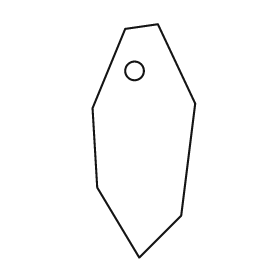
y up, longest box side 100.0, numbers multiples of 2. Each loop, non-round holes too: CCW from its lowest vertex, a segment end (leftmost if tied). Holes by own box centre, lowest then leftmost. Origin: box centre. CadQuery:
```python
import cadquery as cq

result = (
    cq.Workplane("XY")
    .moveTo(-2.0, -50.0)
    .lineTo(16.0, -32.0)
    .lineTo(22.0, 16.0)
    .lineTo(6.0, 50.0)
    .lineTo(-8.0, 48.0)
    .lineTo(-22.0, 14.0)
    .lineTo(-20.0, -20.0)
    .close()
    .moveTo(-4.0, 30.0)
    .circle(4.0)
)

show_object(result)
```